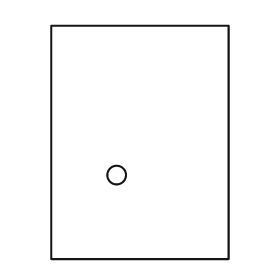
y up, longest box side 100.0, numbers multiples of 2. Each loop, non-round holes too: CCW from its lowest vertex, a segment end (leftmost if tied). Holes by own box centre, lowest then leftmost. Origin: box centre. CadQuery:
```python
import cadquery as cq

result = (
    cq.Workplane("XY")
    .moveTo(-38.0, -50.0)
    .lineTo(38.0, -50.0)
    .lineTo(38.0, 50.0)
    .lineTo(-38.0, 50.0)
    .close()
    .moveTo(-10.0, -14.0)
    .circle(4.0)
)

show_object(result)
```